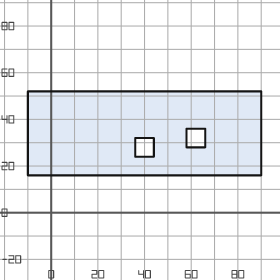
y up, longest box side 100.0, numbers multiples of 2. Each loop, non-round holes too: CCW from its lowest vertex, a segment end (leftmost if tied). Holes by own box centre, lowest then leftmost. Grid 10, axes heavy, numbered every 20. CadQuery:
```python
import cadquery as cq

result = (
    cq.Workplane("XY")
    .moveTo(-10.0, 16.0)
    .lineTo(90.0, 16.0)
    .lineTo(90.0, 52.0)
    .lineTo(-10.0, 52.0)
    .close()
    .moveTo(36.0, 24.0)
    .lineTo(44.0, 24.0)
    .lineTo(44.0, 32.0)
    .lineTo(36.0, 32.0)
    .close()
    .moveTo(58.0, 28.0)
    .lineTo(66.0, 28.0)
    .lineTo(66.0, 36.0)
    .lineTo(58.0, 36.0)
    .close()
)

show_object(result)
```